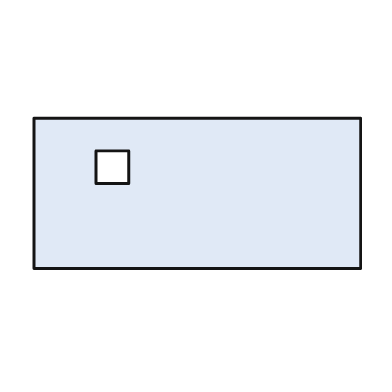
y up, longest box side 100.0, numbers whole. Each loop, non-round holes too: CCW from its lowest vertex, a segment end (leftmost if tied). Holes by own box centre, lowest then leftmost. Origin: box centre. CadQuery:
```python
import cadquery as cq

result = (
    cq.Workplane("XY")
    .moveTo(-50.0, -23.0)
    .lineTo(50.0, -23.0)
    .lineTo(50.0, 23.0)
    .lineTo(-50.0, 23.0)
    .close()
    .moveTo(-31.0, 3.0)
    .lineTo(-21.0, 3.0)
    .lineTo(-21.0, 13.0)
    .lineTo(-31.0, 13.0)
    .close()
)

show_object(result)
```